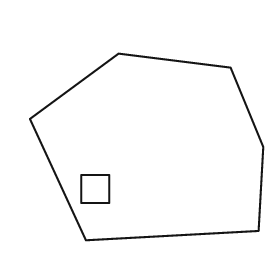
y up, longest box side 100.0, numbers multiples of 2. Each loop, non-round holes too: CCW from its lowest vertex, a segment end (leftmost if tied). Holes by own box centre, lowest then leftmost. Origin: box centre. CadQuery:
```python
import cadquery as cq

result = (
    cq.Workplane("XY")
    .moveTo(-26.0, -40.0)
    .lineTo(48.0, -36.0)
    .lineTo(50.0, 0.0)
    .lineTo(36.0, 34.0)
    .lineTo(-12.0, 40.0)
    .lineTo(-50.0, 12.0)
    .close()
    .moveTo(-28.0, -24.0)
    .lineTo(-16.0, -24.0)
    .lineTo(-16.0, -12.0)
    .lineTo(-28.0, -12.0)
    .close()
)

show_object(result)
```